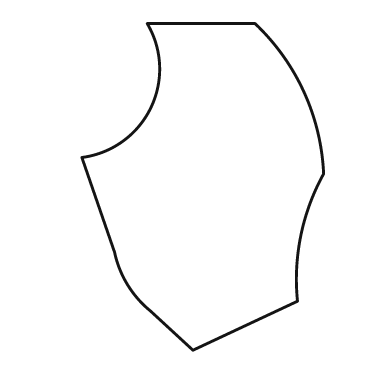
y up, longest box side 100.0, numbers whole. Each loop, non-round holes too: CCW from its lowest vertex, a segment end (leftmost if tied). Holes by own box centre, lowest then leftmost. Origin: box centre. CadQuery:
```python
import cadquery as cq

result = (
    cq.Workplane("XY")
    .moveTo(-3.0, -50.0)
    .lineTo(29.0, -35.0)
    .threePointArc((30.0, -15.0), (37.0, 4.0))
    .threePointArc((31.0, 29.0), (16.0, 50.0))
    .lineTo(-17.0, 50.0)
    .threePointArc((-16.0, 24.0), (-37.0, 9.0))
    .lineTo(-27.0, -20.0)
    .threePointArc((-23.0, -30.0), (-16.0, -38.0))
    .close()
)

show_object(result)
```